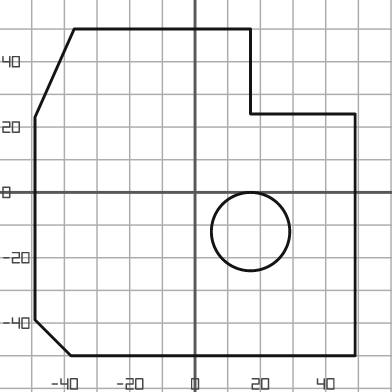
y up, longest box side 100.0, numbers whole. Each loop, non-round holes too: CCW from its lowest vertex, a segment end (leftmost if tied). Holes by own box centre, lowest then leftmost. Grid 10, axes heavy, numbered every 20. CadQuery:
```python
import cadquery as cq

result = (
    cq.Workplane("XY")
    .moveTo(-38.0, -50.0)
    .lineTo(49.0, -50.0)
    .lineTo(49.0, 24.0)
    .lineTo(17.0, 24.0)
    .lineTo(17.0, 50.0)
    .lineTo(-37.0, 50.0)
    .lineTo(-49.0, 23.0)
    .lineTo(-49.0, -39.0)
    .close()
    .moveTo(17.0, -12.0)
    .circle(12.0)
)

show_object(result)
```